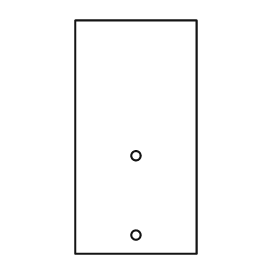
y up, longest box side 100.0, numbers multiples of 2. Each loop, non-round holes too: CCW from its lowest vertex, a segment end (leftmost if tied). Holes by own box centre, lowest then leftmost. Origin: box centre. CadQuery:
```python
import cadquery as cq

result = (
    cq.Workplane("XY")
    .moveTo(-26.0, -50.0)
    .lineTo(26.0, -50.0)
    .lineTo(26.0, 50.0)
    .lineTo(-26.0, 50.0)
    .close()
    .moveTo(0.0, -42.0)
    .circle(2.0)
    .moveTo(0.0, -8.0)
    .circle(2.0)
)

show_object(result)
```